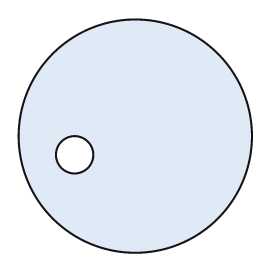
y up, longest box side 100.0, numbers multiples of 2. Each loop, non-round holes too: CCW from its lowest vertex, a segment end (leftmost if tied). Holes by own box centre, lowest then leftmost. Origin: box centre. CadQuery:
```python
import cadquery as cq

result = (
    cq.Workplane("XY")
    .moveTo(0.0, 0.0)
    .circle(50.0)
    .moveTo(-26.0, -8.0)
    .circle(8.0)
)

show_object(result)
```